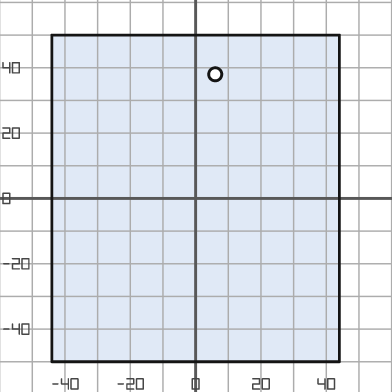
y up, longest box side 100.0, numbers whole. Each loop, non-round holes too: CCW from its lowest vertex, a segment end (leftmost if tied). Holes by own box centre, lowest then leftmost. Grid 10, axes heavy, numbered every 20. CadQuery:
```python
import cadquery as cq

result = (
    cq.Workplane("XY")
    .moveTo(-44.0, -50.0)
    .lineTo(44.0, -50.0)
    .lineTo(44.0, 50.0)
    .lineTo(-44.0, 50.0)
    .close()
    .moveTo(6.0, 38.0)
    .circle(2.0)
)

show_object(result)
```